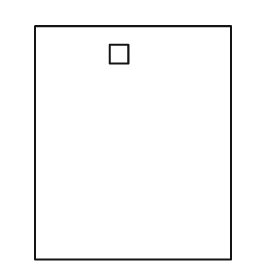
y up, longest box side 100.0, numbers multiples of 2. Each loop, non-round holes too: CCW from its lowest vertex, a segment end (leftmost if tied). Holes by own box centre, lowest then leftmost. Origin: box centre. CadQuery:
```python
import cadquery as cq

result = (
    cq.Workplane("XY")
    .moveTo(-42.0, -50.0)
    .lineTo(42.0, -50.0)
    .lineTo(42.0, 50.0)
    .lineTo(-42.0, 50.0)
    .close()
    .moveTo(-10.0, 34.0)
    .lineTo(-2.0, 34.0)
    .lineTo(-2.0, 42.0)
    .lineTo(-10.0, 42.0)
    .close()
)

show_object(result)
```